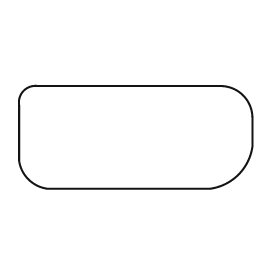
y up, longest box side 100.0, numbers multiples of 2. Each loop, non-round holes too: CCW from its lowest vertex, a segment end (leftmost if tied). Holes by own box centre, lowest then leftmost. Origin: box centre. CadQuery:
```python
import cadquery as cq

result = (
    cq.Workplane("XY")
    .moveTo(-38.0, -22.0)
    .lineTo(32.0, -22.0)
    .threePointArc((44.0, -16.0), (50.0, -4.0))
    .lineTo(50.0, 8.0)
    .threePointArc((46.0, 18.0), (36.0, 22.0))
    .lineTo(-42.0, 22.0)
    .threePointArc((-48.0, 20.0), (-50.0, 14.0))
    .lineTo(-50.0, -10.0)
    .threePointArc((-46.0, -18.0), (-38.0, -22.0))
    .close()
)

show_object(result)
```